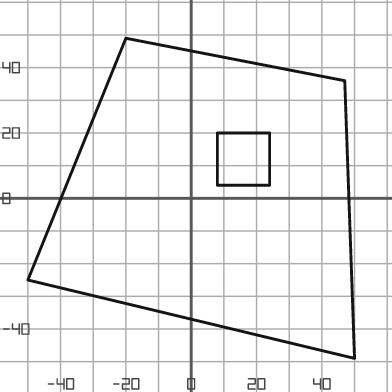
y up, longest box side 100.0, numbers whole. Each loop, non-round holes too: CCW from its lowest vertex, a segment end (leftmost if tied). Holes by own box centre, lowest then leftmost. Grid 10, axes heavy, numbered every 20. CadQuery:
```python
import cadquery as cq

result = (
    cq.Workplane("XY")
    .moveTo(50.0, -49.0)
    .lineTo(47.0, 36.0)
    .lineTo(-20.0, 49.0)
    .lineTo(-50.0, -25.0)
    .close()
    .moveTo(8.0, 4.0)
    .lineTo(24.0, 4.0)
    .lineTo(24.0, 20.0)
    .lineTo(8.0, 20.0)
    .close()
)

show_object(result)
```